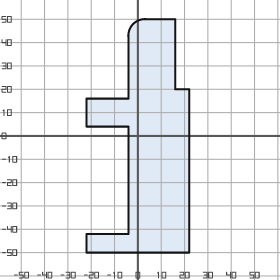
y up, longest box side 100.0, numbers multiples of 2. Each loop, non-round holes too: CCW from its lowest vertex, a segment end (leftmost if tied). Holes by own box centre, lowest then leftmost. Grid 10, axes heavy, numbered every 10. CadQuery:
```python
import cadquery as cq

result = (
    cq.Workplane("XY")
    .moveTo(-22.0, -50.0)
    .lineTo(22.0, -50.0)
    .lineTo(22.0, 20.0)
    .lineTo(16.0, 20.0)
    .lineTo(16.0, 50.0)
    .lineTo(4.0, 50.0)
    .threePointArc((-2.0, 48.0), (-4.0, 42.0))
    .lineTo(-4.0, 16.0)
    .lineTo(-22.0, 16.0)
    .lineTo(-22.0, 4.0)
    .lineTo(-4.0, 4.0)
    .lineTo(-4.0, -42.0)
    .lineTo(-22.0, -42.0)
    .close()
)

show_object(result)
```